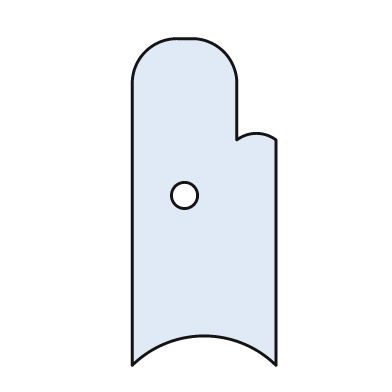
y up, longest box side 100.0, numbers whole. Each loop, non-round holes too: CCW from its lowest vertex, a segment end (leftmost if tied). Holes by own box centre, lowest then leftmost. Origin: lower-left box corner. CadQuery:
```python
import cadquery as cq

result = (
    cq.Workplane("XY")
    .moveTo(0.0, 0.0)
    .threePointArc((22.0, 9.0), (44.0, 0.0))
    .lineTo(44.0, 69.0)
    .threePointArc((38.0, 71.0), (32.0, 69.0))
    .lineTo(32.0, 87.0)
    .threePointArc((28.0, 96.0), (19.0, 100.0))
    .lineTo(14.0, 100.0)
    .threePointArc((4.0, 96.0), (0.0, 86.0))
    .close()
    .moveTo(16.0, 52.0)
    .circle(4.0)
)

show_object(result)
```